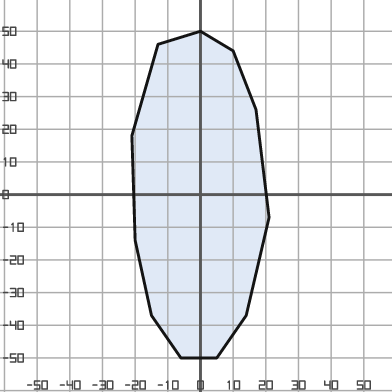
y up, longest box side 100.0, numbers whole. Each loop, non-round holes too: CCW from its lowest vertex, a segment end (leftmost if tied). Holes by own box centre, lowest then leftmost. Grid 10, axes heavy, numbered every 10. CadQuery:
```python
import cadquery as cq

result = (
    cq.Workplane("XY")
    .moveTo(-6.0, -50.0)
    .lineTo(5.0, -50.0)
    .lineTo(14.0, -37.0)
    .lineTo(21.0, -7.0)
    .lineTo(17.0, 26.0)
    .lineTo(10.0, 44.0)
    .lineTo(0.0, 50.0)
    .lineTo(-13.0, 46.0)
    .lineTo(-21.0, 18.0)
    .lineTo(-20.0, -14.0)
    .lineTo(-15.0, -37.0)
    .close()
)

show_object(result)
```